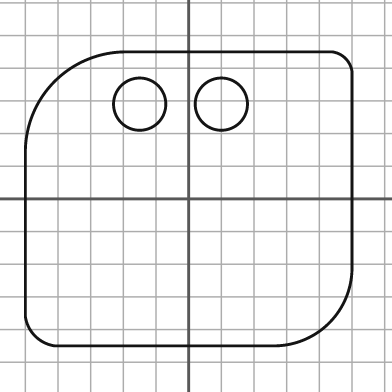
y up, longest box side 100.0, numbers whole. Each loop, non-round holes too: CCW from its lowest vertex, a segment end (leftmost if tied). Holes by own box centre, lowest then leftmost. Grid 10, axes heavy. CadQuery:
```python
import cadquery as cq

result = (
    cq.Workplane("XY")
    .moveTo(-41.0, -45.0)
    .lineTo(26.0, -45.0)
    .threePointArc((43.0, -38.0), (50.0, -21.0))
    .lineTo(50.0, 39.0)
    .threePointArc((48.0, 43.0), (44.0, 45.0))
    .lineTo(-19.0, 45.0)
    .threePointArc((-41.0, 36.0), (-50.0, 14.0))
    .lineTo(-50.0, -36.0)
    .threePointArc((-47.0, -42.0), (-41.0, -45.0))
    .close()
    .moveTo(-15.0, 29.0)
    .circle(8.0)
    .moveTo(10.0, 29.0)
    .circle(8.0)
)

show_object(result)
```